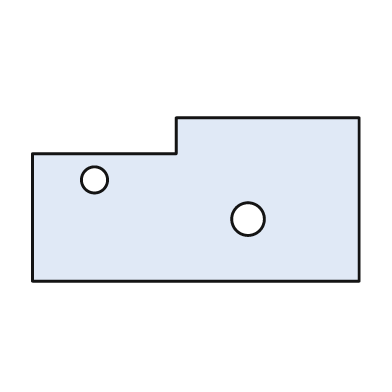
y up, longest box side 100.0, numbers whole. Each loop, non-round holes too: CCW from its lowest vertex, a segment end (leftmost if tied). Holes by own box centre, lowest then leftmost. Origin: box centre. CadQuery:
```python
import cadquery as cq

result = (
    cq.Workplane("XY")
    .moveTo(-50.0, -25.0)
    .lineTo(50.0, -25.0)
    .lineTo(50.0, 25.0)
    .lineTo(-6.0, 25.0)
    .lineTo(-6.0, 14.0)
    .lineTo(-50.0, 14.0)
    .close()
    .moveTo(16.0, -6.0)
    .circle(5.0)
    .moveTo(-31.0, 6.0)
    .circle(4.0)
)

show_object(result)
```